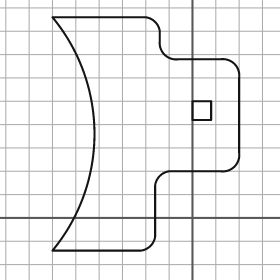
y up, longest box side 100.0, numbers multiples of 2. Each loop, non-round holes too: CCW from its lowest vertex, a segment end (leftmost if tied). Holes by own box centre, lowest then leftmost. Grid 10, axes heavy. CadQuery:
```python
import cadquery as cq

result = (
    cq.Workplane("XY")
    .moveTo(-60.0, -14.0)
    .lineTo(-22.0, -14.0)
    .threePointArc((-18.0, -12.0), (-16.0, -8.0))
    .lineTo(-16.0, 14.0)
    .threePointArc((-14.0, 18.0), (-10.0, 20.0))
    .lineTo(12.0, 20.0)
    .threePointArc((18.0, 22.0), (20.0, 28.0))
    .lineTo(20.0, 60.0)
    .threePointArc((18.0, 66.0), (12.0, 68.0))
    .lineTo(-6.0, 68.0)
    .threePointArc((-12.0, 70.0), (-14.0, 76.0))
    .lineTo(-14.0, 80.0)
    .threePointArc((-16.0, 84.0), (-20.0, 86.0))
    .lineTo(-60.0, 86.0)
    .threePointArc((-42.0, 36.0), (-60.0, -14.0))
    .close()
    .moveTo(0.0, 42.0)
    .lineTo(8.0, 42.0)
    .lineTo(8.0, 50.0)
    .lineTo(0.0, 50.0)
    .close()
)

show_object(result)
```